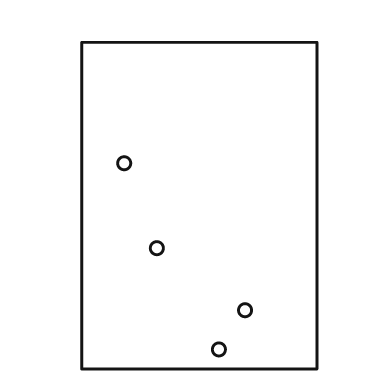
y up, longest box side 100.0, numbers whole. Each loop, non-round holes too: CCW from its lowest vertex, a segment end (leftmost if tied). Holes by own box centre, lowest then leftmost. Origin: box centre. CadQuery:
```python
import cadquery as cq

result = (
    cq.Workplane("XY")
    .moveTo(-36.0, -50.0)
    .lineTo(36.0, -50.0)
    .lineTo(36.0, 50.0)
    .lineTo(-36.0, 50.0)
    .close()
    .moveTo(6.0, -44.0)
    .circle(2.0)
    .moveTo(14.0, -32.0)
    .circle(2.0)
    .moveTo(-13.0, -13.0)
    .circle(2.0)
    .moveTo(-23.0, 13.0)
    .circle(2.0)
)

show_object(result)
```